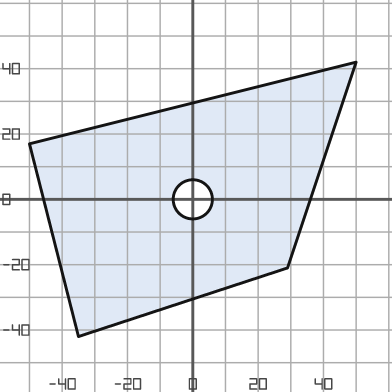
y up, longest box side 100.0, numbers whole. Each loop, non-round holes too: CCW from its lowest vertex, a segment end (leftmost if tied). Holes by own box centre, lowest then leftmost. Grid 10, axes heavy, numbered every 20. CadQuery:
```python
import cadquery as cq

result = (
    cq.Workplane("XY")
    .moveTo(-35.0, -42.0)
    .lineTo(29.0, -21.0)
    .lineTo(50.0, 42.0)
    .lineTo(-50.0, 17.0)
    .close()
    .moveTo(0.0, 0.0)
    .circle(6.0)
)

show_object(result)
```